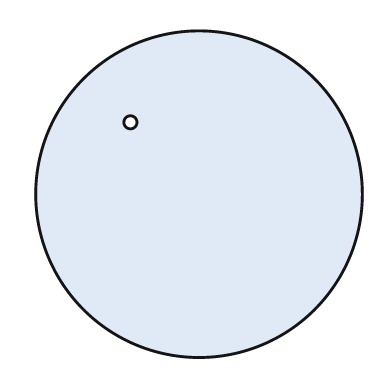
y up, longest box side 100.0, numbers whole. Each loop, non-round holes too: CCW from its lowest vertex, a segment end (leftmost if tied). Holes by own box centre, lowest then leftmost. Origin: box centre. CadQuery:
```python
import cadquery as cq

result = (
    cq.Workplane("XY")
    .moveTo(0.0, 0.0)
    .circle(50.0)
    .moveTo(-21.0, 22.0)
    .circle(2.0)
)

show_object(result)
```